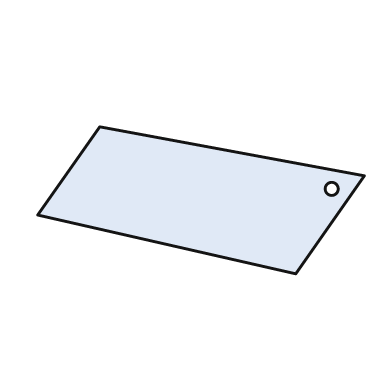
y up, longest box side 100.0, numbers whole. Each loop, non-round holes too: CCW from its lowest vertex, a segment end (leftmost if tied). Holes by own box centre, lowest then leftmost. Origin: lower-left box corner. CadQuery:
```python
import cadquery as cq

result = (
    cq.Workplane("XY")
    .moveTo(79.0, 0.0)
    .lineTo(100.0, 30.0)
    .lineTo(19.0, 45.0)
    .lineTo(0.0, 18.0)
    .close()
    .moveTo(90.0, 26.0)
    .circle(2.0)
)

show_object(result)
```